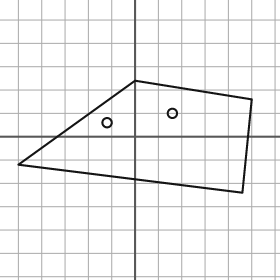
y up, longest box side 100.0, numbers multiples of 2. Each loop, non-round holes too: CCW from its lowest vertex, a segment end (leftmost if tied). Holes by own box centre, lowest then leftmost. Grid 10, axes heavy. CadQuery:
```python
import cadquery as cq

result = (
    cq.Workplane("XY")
    .moveTo(46.0, -24.0)
    .lineTo(50.0, 16.0)
    .lineTo(0.0, 24.0)
    .lineTo(-50.0, -12.0)
    .close()
    .moveTo(-12.0, 6.0)
    .circle(2.0)
    .moveTo(16.0, 10.0)
    .circle(2.0)
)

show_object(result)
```